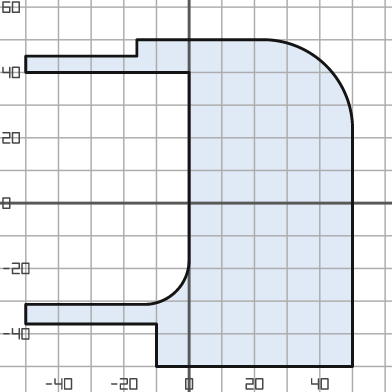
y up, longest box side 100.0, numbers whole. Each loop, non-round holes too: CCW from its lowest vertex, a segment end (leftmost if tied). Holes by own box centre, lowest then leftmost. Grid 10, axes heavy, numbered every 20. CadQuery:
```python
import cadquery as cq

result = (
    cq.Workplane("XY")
    .moveTo(-10.0, -50.0)
    .lineTo(50.0, -50.0)
    .lineTo(50.0, 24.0)
    .threePointArc((42.0, 42.0), (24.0, 50.0))
    .lineTo(-16.0, 50.0)
    .lineTo(-16.0, 45.0)
    .lineTo(-50.0, 45.0)
    .lineTo(-50.0, 40.0)
    .lineTo(0.0, 40.0)
    .lineTo(0.0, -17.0)
    .threePointArc((-4.0, -27.0), (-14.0, -31.0))
    .lineTo(-50.0, -31.0)
    .lineTo(-50.0, -37.0)
    .lineTo(-10.0, -37.0)
    .close()
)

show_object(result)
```